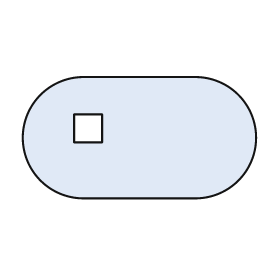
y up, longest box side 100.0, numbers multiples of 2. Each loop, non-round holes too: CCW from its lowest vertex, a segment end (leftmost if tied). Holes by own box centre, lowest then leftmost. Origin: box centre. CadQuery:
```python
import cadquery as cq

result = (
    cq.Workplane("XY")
    .moveTo(-24.0, -26.0)
    .lineTo(24.0, -26.0)
    .threePointArc((50.0, 0.0), (24.0, 26.0))
    .lineTo(-24.0, 26.0)
    .threePointArc((-50.0, 0.0), (-24.0, -26.0))
    .close()
    .moveTo(-28.0, -2.0)
    .lineTo(-16.0, -2.0)
    .lineTo(-16.0, 10.0)
    .lineTo(-28.0, 10.0)
    .close()
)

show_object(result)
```